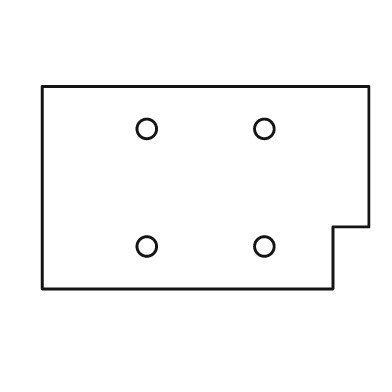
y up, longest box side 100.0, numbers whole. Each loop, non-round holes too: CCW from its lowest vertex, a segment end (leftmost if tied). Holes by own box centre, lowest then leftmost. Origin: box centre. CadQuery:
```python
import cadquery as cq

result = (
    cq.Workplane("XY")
    .moveTo(-50.0, -31.0)
    .lineTo(39.0, -31.0)
    .lineTo(39.0, -12.0)
    .lineTo(50.0, -12.0)
    .lineTo(50.0, 31.0)
    .lineTo(-50.0, 31.0)
    .close()
    .moveTo(-18.0, -18.0)
    .circle(3.0)
    .moveTo(18.0, -18.0)
    .circle(3.0)
    .moveTo(-18.0, 18.0)
    .circle(3.0)
    .moveTo(18.0, 18.0)
    .circle(3.0)
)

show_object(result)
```